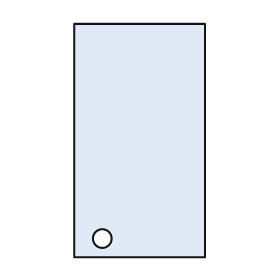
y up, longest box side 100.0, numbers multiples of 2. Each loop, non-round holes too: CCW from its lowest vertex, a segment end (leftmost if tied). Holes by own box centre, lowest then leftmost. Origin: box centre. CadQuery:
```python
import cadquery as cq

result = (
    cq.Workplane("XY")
    .moveTo(-28.0, -50.0)
    .lineTo(28.0, -50.0)
    .lineTo(28.0, 50.0)
    .lineTo(-28.0, 50.0)
    .close()
    .moveTo(-16.0, -42.0)
    .circle(4.0)
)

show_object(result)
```